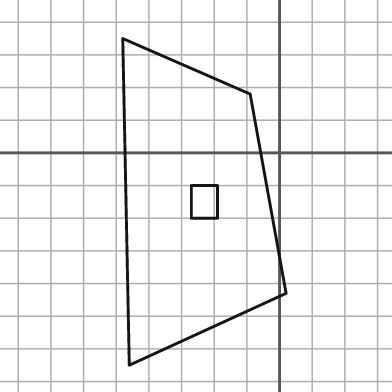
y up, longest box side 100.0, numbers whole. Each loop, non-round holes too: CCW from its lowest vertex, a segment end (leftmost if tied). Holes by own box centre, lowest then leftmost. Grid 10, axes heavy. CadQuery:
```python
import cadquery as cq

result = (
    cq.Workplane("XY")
    .moveTo(-46.0, -65.0)
    .lineTo(2.0, -43.0)
    .lineTo(-9.0, 18.0)
    .lineTo(-48.0, 35.0)
    .close()
    .moveTo(-27.0, -20.0)
    .lineTo(-19.0, -20.0)
    .lineTo(-19.0, -10.0)
    .lineTo(-27.0, -10.0)
    .close()
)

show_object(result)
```